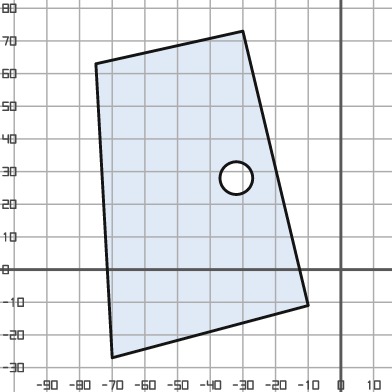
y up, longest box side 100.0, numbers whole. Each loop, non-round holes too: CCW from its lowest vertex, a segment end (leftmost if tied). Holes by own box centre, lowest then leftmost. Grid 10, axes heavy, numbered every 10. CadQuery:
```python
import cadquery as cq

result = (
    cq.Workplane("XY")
    .moveTo(-70.0, -27.0)
    .lineTo(-10.0, -11.0)
    .lineTo(-30.0, 73.0)
    .lineTo(-75.0, 63.0)
    .close()
    .moveTo(-32.0, 28.0)
    .circle(5.0)
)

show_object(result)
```